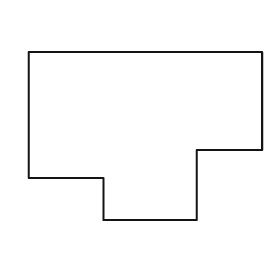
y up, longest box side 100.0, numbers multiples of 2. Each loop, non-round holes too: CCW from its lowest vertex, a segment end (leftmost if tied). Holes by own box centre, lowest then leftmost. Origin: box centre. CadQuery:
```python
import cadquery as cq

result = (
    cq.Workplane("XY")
    .moveTo(-18.0, -36.0)
    .lineTo(22.0, -36.0)
    .lineTo(22.0, -6.0)
    .lineTo(50.0, -6.0)
    .lineTo(50.0, 36.0)
    .lineTo(-50.0, 36.0)
    .lineTo(-50.0, -18.0)
    .lineTo(-18.0, -18.0)
    .close()
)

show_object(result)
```